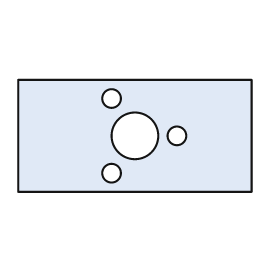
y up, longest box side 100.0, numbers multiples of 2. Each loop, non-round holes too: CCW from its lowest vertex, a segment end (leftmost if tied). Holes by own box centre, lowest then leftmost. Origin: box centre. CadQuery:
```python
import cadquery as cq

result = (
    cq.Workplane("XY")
    .moveTo(-50.0, -24.0)
    .lineTo(50.0, -24.0)
    .lineTo(50.0, 24.0)
    .lineTo(-50.0, 24.0)
    .close()
    .moveTo(-10.0, -16.0)
    .circle(4.0)
    .moveTo(0.0, 0.0)
    .circle(10.0)
    .moveTo(18.0, 0.0)
    .circle(4.0)
    .moveTo(-10.0, 16.0)
    .circle(4.0)
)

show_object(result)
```